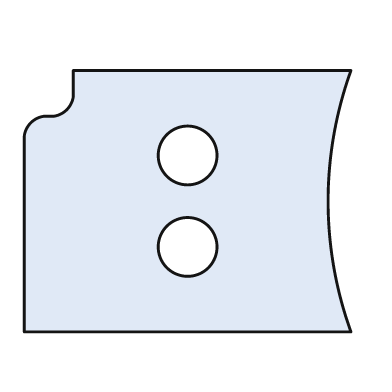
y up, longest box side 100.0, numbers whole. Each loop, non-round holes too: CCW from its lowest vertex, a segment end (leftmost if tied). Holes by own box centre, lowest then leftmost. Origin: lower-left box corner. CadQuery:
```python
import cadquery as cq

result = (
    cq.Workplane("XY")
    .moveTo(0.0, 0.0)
    .lineTo(100.0, 0.0)
    .threePointArc((93.0, 40.0), (100.0, 80.0))
    .lineTo(15.0, 80.0)
    .lineTo(15.0, 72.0)
    .threePointArc((13.0, 68.0), (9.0, 66.0))
    .lineTo(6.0, 66.0)
    .threePointArc((2.0, 64.0), (0.0, 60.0))
    .close()
    .moveTo(50.0, 26.0)
    .circle(9.0)
    .moveTo(50.0, 54.0)
    .circle(9.0)
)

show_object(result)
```